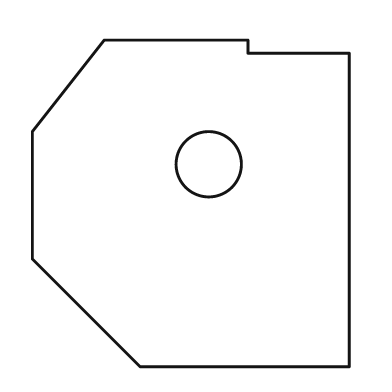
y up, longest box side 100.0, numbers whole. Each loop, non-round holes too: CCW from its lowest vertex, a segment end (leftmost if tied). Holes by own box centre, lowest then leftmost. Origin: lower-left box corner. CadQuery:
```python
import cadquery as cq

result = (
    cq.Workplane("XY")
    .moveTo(33.0, 0.0)
    .lineTo(97.0, 0.0)
    .lineTo(97.0, 96.0)
    .lineTo(66.0, 96.0)
    .lineTo(66.0, 100.0)
    .lineTo(22.0, 100.0)
    .lineTo(0.0, 72.0)
    .lineTo(0.0, 33.0)
    .close()
    .moveTo(54.0, 62.0)
    .circle(10.0)
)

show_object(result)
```